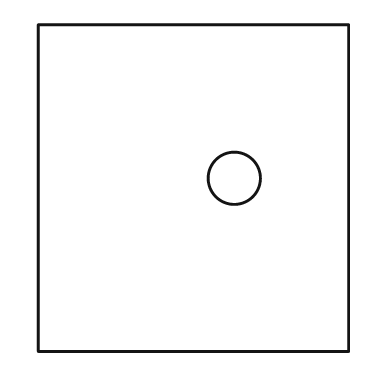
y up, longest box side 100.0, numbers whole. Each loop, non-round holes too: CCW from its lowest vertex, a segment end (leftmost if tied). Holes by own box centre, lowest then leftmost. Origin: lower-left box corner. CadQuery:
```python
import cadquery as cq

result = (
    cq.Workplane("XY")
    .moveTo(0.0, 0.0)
    .lineTo(95.0, 0.0)
    .lineTo(95.0, 100.0)
    .lineTo(0.0, 100.0)
    .close()
    .moveTo(60.0, 53.0)
    .circle(8.0)
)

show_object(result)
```